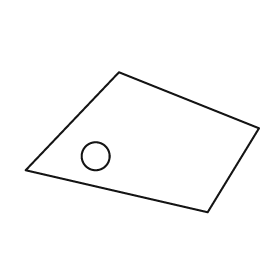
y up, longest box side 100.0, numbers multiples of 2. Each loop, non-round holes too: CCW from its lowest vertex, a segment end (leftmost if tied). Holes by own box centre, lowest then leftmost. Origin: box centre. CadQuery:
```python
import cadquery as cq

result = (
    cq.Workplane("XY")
    .moveTo(28.0, -30.0)
    .lineTo(50.0, 6.0)
    .lineTo(-10.0, 30.0)
    .lineTo(-50.0, -12.0)
    .close()
    .moveTo(-20.0, -6.0)
    .circle(6.0)
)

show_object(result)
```